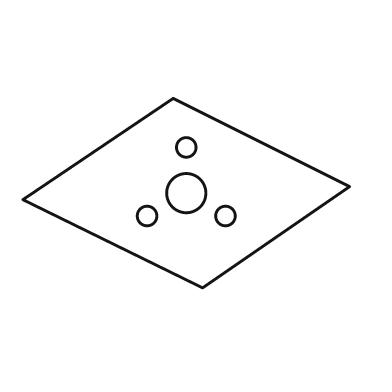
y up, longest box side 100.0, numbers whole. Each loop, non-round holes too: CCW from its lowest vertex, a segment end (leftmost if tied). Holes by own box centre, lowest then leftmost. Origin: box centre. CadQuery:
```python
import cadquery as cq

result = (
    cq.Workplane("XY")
    .moveTo(5.0, -29.0)
    .lineTo(50.0, 2.0)
    .lineTo(-4.0, 29.0)
    .lineTo(-50.0, -2.0)
    .close()
    .moveTo(-12.0, -7.0)
    .circle(3.0)
    .moveTo(12.0, -7.0)
    .circle(3.0)
    .moveTo(0.0, 0.0)
    .circle(6.0)
    .moveTo(0.0, 14.0)
    .circle(3.0)
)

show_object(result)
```